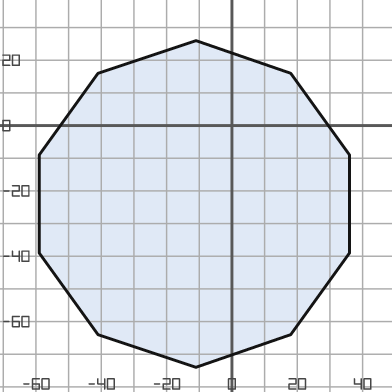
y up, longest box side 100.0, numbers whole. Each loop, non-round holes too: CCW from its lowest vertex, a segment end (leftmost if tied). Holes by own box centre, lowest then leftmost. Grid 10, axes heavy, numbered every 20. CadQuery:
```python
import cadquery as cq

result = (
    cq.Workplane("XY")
    .moveTo(-11.0, -74.0)
    .lineTo(18.0, -64.0)
    .lineTo(36.0, -39.0)
    .lineTo(36.0, -9.0)
    .lineTo(18.0, 16.0)
    .lineTo(-11.0, 26.0)
    .lineTo(-41.0, 16.0)
    .lineTo(-59.0, -9.0)
    .lineTo(-59.0, -39.0)
    .lineTo(-41.0, -64.0)
    .close()
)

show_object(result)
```